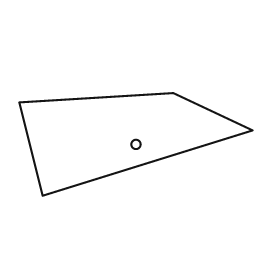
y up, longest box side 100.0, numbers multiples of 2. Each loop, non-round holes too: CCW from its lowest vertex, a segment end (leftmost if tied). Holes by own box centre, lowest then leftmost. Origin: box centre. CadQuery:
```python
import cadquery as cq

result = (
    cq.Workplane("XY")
    .moveTo(-40.0, -22.0)
    .lineTo(50.0, 6.0)
    .lineTo(16.0, 22.0)
    .lineTo(-50.0, 18.0)
    .close()
    .moveTo(0.0, 0.0)
    .circle(2.0)
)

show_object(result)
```